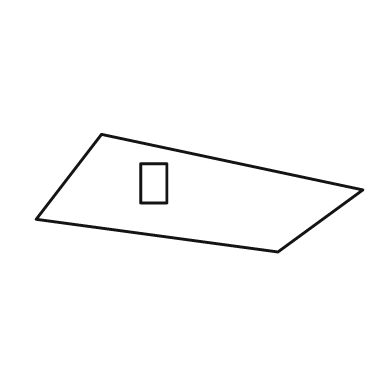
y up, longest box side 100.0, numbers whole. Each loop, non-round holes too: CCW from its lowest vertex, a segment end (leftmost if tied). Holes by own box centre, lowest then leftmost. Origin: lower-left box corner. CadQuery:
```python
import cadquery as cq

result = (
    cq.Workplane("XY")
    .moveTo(74.0, 0.0)
    .lineTo(100.0, 19.0)
    .lineTo(20.0, 36.0)
    .lineTo(0.0, 10.0)
    .close()
    .moveTo(32.0, 15.0)
    .lineTo(40.0, 15.0)
    .lineTo(40.0, 27.0)
    .lineTo(32.0, 27.0)
    .close()
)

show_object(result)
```